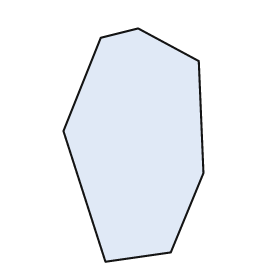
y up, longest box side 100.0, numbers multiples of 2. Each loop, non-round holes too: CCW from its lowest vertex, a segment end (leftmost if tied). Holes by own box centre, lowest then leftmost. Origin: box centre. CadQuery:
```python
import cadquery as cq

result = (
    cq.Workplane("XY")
    .moveTo(-12.0, -50.0)
    .lineTo(16.0, -46.0)
    .lineTo(30.0, -12.0)
    .lineTo(28.0, 36.0)
    .lineTo(2.0, 50.0)
    .lineTo(-14.0, 46.0)
    .lineTo(-30.0, 6.0)
    .close()
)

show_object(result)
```